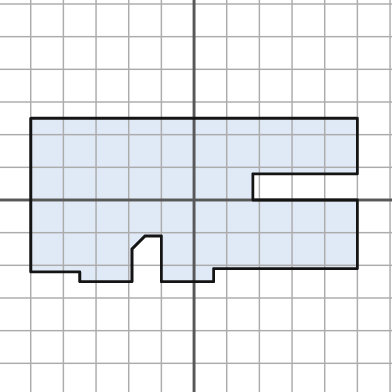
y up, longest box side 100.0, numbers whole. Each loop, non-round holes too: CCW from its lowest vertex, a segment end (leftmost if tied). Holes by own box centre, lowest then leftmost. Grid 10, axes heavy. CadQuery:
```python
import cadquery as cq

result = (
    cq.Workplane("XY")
    .moveTo(-35.0, -25.0)
    .lineTo(-19.0, -25.0)
    .lineTo(-19.0, -15.0)
    .lineTo(-15.0, -11.0)
    .lineTo(-10.0, -11.0)
    .lineTo(-10.0, -25.0)
    .lineTo(6.0, -25.0)
    .lineTo(6.0, -21.0)
    .lineTo(50.0, -21.0)
    .lineTo(50.0, 0.0)
    .lineTo(18.0, 0.0)
    .lineTo(18.0, 8.0)
    .lineTo(50.0, 8.0)
    .lineTo(50.0, 25.0)
    .lineTo(-50.0, 25.0)
    .lineTo(-50.0, -22.0)
    .lineTo(-35.0, -22.0)
    .close()
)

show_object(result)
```